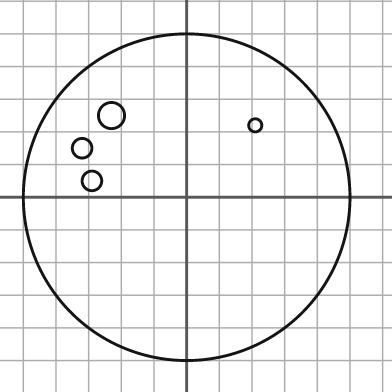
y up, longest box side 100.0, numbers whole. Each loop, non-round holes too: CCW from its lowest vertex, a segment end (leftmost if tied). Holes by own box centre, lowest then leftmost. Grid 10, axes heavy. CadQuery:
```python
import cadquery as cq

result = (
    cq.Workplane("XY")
    .moveTo(0.0, 0.0)
    .circle(50.0)
    .moveTo(-29.0, 5.0)
    .circle(3.0)
    .moveTo(-32.0, 15.0)
    .circle(3.0)
    .moveTo(21.0, 22.0)
    .circle(2.0)
    .moveTo(-23.0, 25.0)
    .circle(4.0)
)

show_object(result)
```